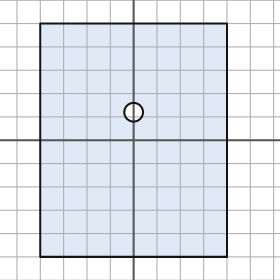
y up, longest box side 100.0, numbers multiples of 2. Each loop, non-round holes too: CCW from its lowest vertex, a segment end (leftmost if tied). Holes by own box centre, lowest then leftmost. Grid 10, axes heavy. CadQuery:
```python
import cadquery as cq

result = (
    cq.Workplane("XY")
    .moveTo(-40.0, -50.0)
    .lineTo(40.0, -50.0)
    .lineTo(40.0, 50.0)
    .lineTo(-40.0, 50.0)
    .close()
    .moveTo(0.0, 12.0)
    .circle(4.0)
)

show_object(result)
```